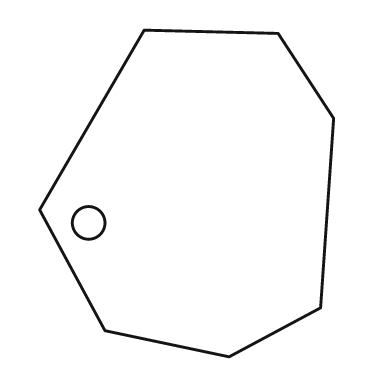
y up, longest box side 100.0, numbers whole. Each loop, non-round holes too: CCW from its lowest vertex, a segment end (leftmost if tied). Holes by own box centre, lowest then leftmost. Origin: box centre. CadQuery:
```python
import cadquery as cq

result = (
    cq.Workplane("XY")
    .moveTo(13.0, -50.0)
    .lineTo(41.0, -35.0)
    .lineTo(45.0, 23.0)
    .lineTo(28.0, 49.0)
    .lineTo(-13.0, 50.0)
    .lineTo(-45.0, -5.0)
    .lineTo(-25.0, -42.0)
    .close()
    .moveTo(-30.0, -9.0)
    .circle(5.0)
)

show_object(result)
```